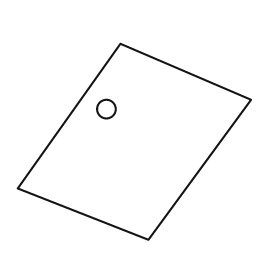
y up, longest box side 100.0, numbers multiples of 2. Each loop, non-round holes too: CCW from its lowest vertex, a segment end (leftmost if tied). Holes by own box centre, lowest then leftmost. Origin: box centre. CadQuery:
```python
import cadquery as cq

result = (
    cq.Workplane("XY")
    .moveTo(6.0, -42.0)
    .lineTo(50.0, 18.0)
    .lineTo(-6.0, 42.0)
    .lineTo(-50.0, -20.0)
    .close()
    .moveTo(-12.0, 14.0)
    .circle(4.0)
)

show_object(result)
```